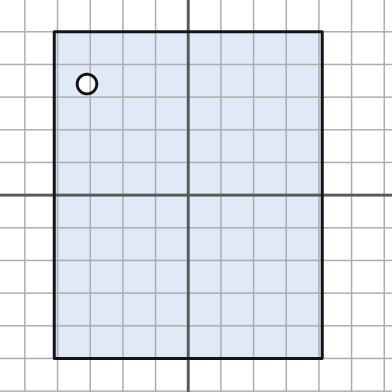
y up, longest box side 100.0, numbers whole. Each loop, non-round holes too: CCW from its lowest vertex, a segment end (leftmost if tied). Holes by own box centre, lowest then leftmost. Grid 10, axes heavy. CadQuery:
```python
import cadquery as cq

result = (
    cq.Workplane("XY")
    .moveTo(-41.0, -50.0)
    .lineTo(41.0, -50.0)
    .lineTo(41.0, 50.0)
    .lineTo(-41.0, 50.0)
    .close()
    .moveTo(-31.0, 34.0)
    .circle(3.0)
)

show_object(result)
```